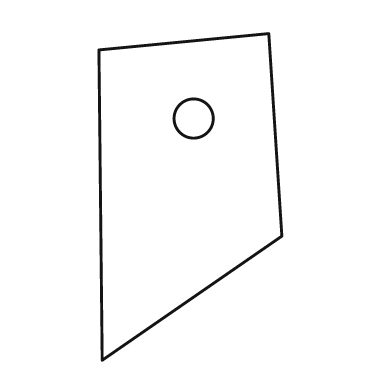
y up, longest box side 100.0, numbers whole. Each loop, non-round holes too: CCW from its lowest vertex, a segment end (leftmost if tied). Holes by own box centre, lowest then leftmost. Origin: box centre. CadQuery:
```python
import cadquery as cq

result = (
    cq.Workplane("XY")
    .moveTo(-27.0, -50.0)
    .lineTo(28.0, -12.0)
    .lineTo(24.0, 50.0)
    .lineTo(-28.0, 45.0)
    .close()
    .moveTo(1.0, 24.0)
    .circle(6.0)
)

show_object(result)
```